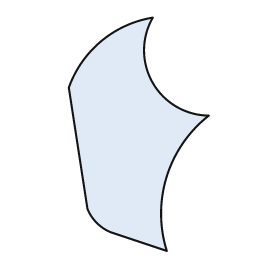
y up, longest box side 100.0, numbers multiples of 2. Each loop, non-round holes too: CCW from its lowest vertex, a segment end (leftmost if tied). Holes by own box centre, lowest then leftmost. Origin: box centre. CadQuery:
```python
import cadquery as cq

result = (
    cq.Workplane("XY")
    .moveTo(12.0, -50.0)
    .threePointArc((12.0, -18.0), (30.0, 8.0))
    .threePointArc((6.0, 22.0), (6.0, 50.0))
    .threePointArc((-16.0, 40.0), (-30.0, 20.0))
    .lineTo(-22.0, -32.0)
    .threePointArc((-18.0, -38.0), (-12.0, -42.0))
    .close()
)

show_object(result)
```